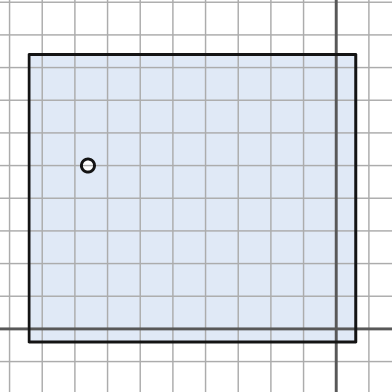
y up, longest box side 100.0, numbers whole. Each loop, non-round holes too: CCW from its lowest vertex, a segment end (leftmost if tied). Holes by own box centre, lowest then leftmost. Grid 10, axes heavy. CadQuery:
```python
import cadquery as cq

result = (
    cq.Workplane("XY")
    .moveTo(-94.0, -4.0)
    .lineTo(6.0, -4.0)
    .lineTo(6.0, 84.0)
    .lineTo(-94.0, 84.0)
    .close()
    .moveTo(-76.0, 50.0)
    .circle(2.0)
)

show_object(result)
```